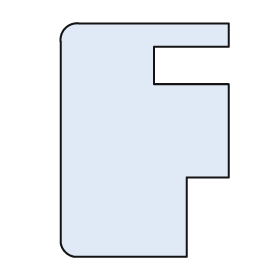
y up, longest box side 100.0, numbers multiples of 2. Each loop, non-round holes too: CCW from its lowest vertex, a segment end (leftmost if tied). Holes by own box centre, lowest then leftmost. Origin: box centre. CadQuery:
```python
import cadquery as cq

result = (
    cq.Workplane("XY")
    .moveTo(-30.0, -50.0)
    .lineTo(18.0, -50.0)
    .lineTo(18.0, -16.0)
    .lineTo(36.0, -16.0)
    .lineTo(36.0, 24.0)
    .lineTo(4.0, 24.0)
    .lineTo(4.0, 40.0)
    .lineTo(36.0, 40.0)
    .lineTo(36.0, 50.0)
    .lineTo(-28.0, 50.0)
    .threePointArc((-34.0, 48.0), (-36.0, 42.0))
    .lineTo(-36.0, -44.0)
    .threePointArc((-34.0, -48.0), (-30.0, -50.0))
    .close()
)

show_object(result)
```